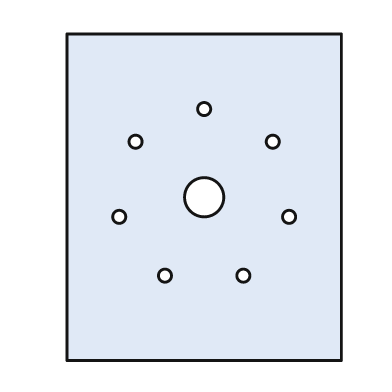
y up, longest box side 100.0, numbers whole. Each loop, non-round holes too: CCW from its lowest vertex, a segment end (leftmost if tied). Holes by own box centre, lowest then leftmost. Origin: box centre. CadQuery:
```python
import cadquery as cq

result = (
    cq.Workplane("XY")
    .moveTo(-42.0, -50.0)
    .lineTo(42.0, -50.0)
    .lineTo(42.0, 50.0)
    .lineTo(-42.0, 50.0)
    .close()
    .moveTo(-12.0, -24.0)
    .circle(2.0)
    .moveTo(12.0, -24.0)
    .circle(2.0)
    .moveTo(-26.0, -6.0)
    .circle(2.0)
    .moveTo(26.0, -6.0)
    .circle(2.0)
    .moveTo(0.0, 0.0)
    .circle(6.0)
    .moveTo(-21.0, 17.0)
    .circle(2.0)
    .moveTo(21.0, 17.0)
    .circle(2.0)
    .moveTo(0.0, 27.0)
    .circle(2.0)
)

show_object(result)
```